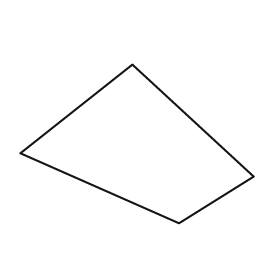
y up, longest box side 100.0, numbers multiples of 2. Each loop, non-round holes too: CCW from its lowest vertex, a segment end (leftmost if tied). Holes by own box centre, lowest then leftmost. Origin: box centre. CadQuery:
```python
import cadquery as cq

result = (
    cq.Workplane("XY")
    .moveTo(18.0, -34.0)
    .lineTo(50.0, -14.0)
    .lineTo(-2.0, 34.0)
    .lineTo(-50.0, -4.0)
    .close()
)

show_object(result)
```